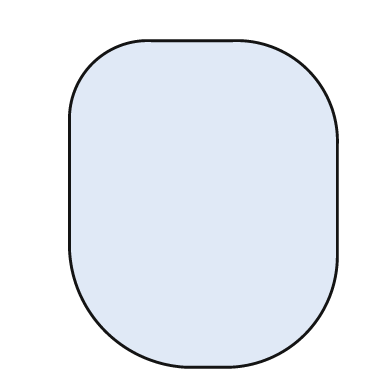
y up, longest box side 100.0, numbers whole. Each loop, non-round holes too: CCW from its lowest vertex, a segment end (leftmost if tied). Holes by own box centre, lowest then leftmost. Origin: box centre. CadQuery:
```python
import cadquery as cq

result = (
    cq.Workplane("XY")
    .moveTo(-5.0, -50.0)
    .lineTo(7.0, -50.0)
    .threePointArc((31.0, -40.0), (41.0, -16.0))
    .lineTo(41.0, 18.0)
    .threePointArc((32.0, 41.0), (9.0, 50.0))
    .lineTo(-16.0, 50.0)
    .threePointArc((-34.0, 43.0), (-41.0, 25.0))
    .lineTo(-41.0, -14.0)
    .threePointArc((-30.0, -39.0), (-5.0, -50.0))
    .close()
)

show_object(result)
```